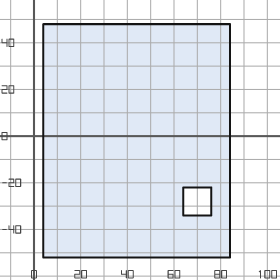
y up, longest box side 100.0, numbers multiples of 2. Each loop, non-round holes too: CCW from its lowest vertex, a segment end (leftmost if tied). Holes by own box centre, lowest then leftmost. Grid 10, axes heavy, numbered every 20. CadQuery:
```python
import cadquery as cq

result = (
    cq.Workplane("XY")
    .moveTo(4.0, -52.0)
    .lineTo(84.0, -52.0)
    .lineTo(84.0, 48.0)
    .lineTo(4.0, 48.0)
    .close()
    .moveTo(64.0, -34.0)
    .lineTo(76.0, -34.0)
    .lineTo(76.0, -22.0)
    .lineTo(64.0, -22.0)
    .close()
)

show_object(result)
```